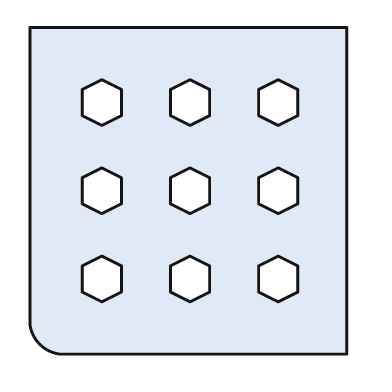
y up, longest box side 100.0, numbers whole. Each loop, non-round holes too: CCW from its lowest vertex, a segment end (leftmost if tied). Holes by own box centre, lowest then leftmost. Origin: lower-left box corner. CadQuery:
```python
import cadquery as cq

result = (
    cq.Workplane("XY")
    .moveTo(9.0, 0.0)
    .lineTo(97.0, 0.0)
    .lineTo(97.0, 100.0)
    .lineTo(0.0, 100.0)
    .lineTo(0.0, 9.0)
    .threePointArc((3.0, 3.0), (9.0, 0.0))
    .close()
    .moveTo(22.0, 16.0)
    .lineTo(28.0, 19.0)
    .lineTo(28.0, 27.0)
    .lineTo(22.0, 30.0)
    .lineTo(16.0, 27.0)
    .lineTo(16.0, 19.0)
    .close()
    .moveTo(49.0, 16.0)
    .lineTo(55.0, 19.0)
    .lineTo(55.0, 27.0)
    .lineTo(49.0, 30.0)
    .lineTo(43.0, 27.0)
    .lineTo(43.0, 19.0)
    .close()
    .moveTo(76.0, 16.0)
    .lineTo(82.0, 19.0)
    .lineTo(82.0, 27.0)
    .lineTo(76.0, 30.0)
    .lineTo(70.0, 27.0)
    .lineTo(70.0, 19.0)
    .close()
    .moveTo(22.0, 43.0)
    .lineTo(28.0, 46.0)
    .lineTo(28.0, 54.0)
    .lineTo(22.0, 57.0)
    .lineTo(16.0, 54.0)
    .lineTo(16.0, 46.0)
    .close()
    .moveTo(49.0, 43.0)
    .lineTo(55.0, 46.0)
    .lineTo(55.0, 54.0)
    .lineTo(49.0, 57.0)
    .lineTo(43.0, 54.0)
    .lineTo(43.0, 46.0)
    .close()
    .moveTo(76.0, 43.0)
    .lineTo(82.0, 46.0)
    .lineTo(82.0, 54.0)
    .lineTo(76.0, 57.0)
    .lineTo(70.0, 54.0)
    .lineTo(70.0, 46.0)
    .close()
    .moveTo(22.0, 70.0)
    .lineTo(28.0, 73.0)
    .lineTo(28.0, 81.0)
    .lineTo(22.0, 84.0)
    .lineTo(16.0, 81.0)
    .lineTo(16.0, 73.0)
    .close()
    .moveTo(49.0, 70.0)
    .lineTo(55.0, 73.0)
    .lineTo(55.0, 81.0)
    .lineTo(49.0, 84.0)
    .lineTo(43.0, 81.0)
    .lineTo(43.0, 73.0)
    .close()
    .moveTo(76.0, 70.0)
    .lineTo(82.0, 73.0)
    .lineTo(82.0, 81.0)
    .lineTo(76.0, 84.0)
    .lineTo(70.0, 81.0)
    .lineTo(70.0, 73.0)
    .close()
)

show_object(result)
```